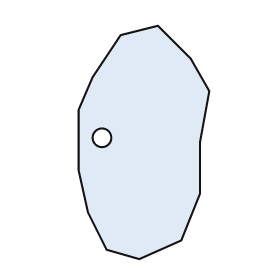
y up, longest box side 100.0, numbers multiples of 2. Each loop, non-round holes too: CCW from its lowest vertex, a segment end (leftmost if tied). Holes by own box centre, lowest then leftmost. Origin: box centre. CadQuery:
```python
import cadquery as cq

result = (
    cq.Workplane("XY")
    .moveTo(-2.0, -50.0)
    .lineTo(16.0, -42.0)
    .lineTo(24.0, -22.0)
    .lineTo(24.0, 0.0)
    .lineTo(28.0, 22.0)
    .lineTo(20.0, 36.0)
    .lineTo(6.0, 50.0)
    .lineTo(-10.0, 46.0)
    .lineTo(-22.0, 28.0)
    .lineTo(-28.0, 14.0)
    .lineTo(-28.0, -12.0)
    .lineTo(-24.0, -30.0)
    .lineTo(-16.0, -46.0)
    .close()
    .moveTo(-18.0, 2.0)
    .circle(4.0)
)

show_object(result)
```